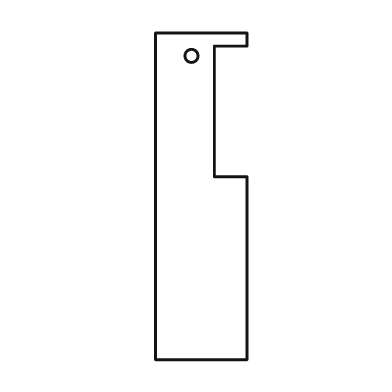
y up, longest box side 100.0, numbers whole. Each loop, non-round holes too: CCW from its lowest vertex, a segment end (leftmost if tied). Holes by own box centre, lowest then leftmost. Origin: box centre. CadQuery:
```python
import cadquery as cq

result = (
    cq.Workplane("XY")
    .moveTo(-14.0, -50.0)
    .lineTo(14.0, -50.0)
    .lineTo(14.0, 6.0)
    .lineTo(4.0, 6.0)
    .lineTo(4.0, 46.0)
    .lineTo(14.0, 46.0)
    .lineTo(14.0, 50.0)
    .lineTo(-14.0, 50.0)
    .close()
    .moveTo(-3.0, 43.0)
    .circle(2.0)
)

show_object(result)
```